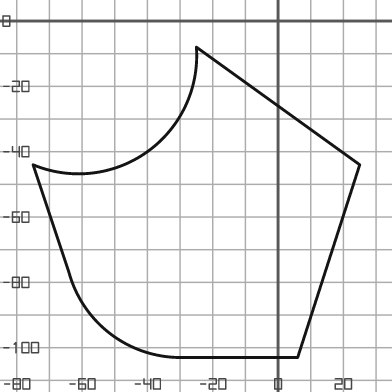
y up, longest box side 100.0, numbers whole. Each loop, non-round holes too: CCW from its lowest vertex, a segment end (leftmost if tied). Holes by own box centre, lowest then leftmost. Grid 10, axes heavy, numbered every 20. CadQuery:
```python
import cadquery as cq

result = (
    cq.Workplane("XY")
    .moveTo(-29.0, -103.0)
    .lineTo(6.0, -103.0)
    .lineTo(25.0, -44.0)
    .lineTo(-25.0, -8.0)
    .threePointArc((-40.0, -40.0), (-75.0, -44.0))
    .lineTo(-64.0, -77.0)
    .threePointArc((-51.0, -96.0), (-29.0, -103.0))
    .close()
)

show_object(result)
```